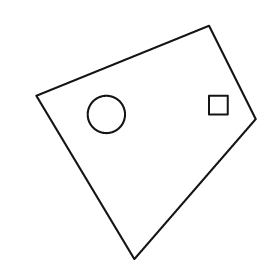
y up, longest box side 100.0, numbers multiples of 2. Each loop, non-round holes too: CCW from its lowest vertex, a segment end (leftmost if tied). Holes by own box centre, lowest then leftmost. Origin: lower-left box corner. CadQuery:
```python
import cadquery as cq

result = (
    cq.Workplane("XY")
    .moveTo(42.0, 0.0)
    .lineTo(94.0, 60.0)
    .lineTo(74.0, 100.0)
    .lineTo(0.0, 70.0)
    .close()
    .moveTo(30.0, 62.0)
    .circle(8.0)
    .moveTo(74.0, 62.0)
    .lineTo(82.0, 62.0)
    .lineTo(82.0, 70.0)
    .lineTo(74.0, 70.0)
    .close()
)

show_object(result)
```